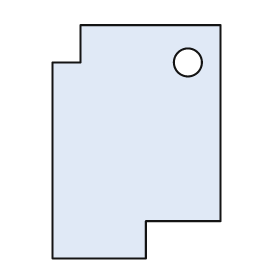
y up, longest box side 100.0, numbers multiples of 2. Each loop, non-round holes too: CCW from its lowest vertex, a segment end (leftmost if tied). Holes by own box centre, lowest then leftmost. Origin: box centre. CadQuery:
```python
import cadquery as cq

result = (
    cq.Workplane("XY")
    .moveTo(-36.0, -50.0)
    .lineTo(4.0, -50.0)
    .lineTo(4.0, -34.0)
    .lineTo(36.0, -34.0)
    .lineTo(36.0, 50.0)
    .lineTo(-24.0, 50.0)
    .lineTo(-24.0, 34.0)
    .lineTo(-36.0, 34.0)
    .close()
    .moveTo(22.0, 34.0)
    .circle(6.0)
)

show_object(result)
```